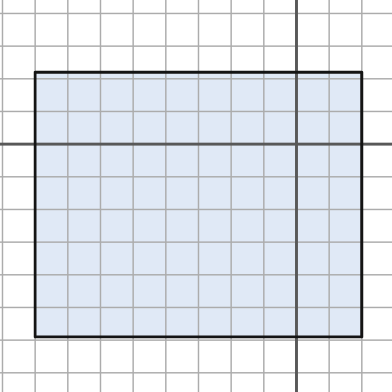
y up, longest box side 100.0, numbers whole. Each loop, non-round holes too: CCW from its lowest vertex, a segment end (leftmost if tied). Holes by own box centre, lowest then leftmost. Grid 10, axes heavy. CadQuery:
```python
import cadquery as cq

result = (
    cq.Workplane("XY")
    .moveTo(-80.0, -59.0)
    .lineTo(20.0, -59.0)
    .lineTo(20.0, 22.0)
    .lineTo(-80.0, 22.0)
    .close()
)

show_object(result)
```